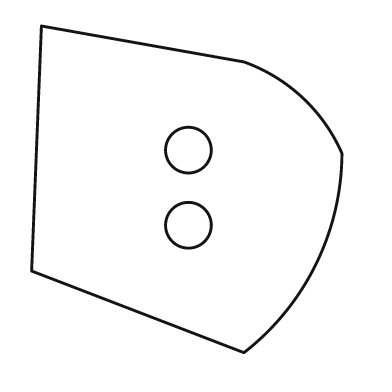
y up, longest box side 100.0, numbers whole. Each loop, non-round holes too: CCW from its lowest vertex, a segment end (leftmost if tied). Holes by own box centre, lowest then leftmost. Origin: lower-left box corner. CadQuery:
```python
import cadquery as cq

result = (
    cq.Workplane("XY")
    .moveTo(65.0, 0.0)
    .threePointArc((87.0, 27.0), (95.0, 61.0))
    .threePointArc((83.0, 78.0), (65.0, 89.0))
    .lineTo(3.0, 100.0)
    .lineTo(0.0, 25.0)
    .close()
    .moveTo(48.0, 39.0)
    .circle(7.0)
    .moveTo(48.0, 62.0)
    .circle(7.0)
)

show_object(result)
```